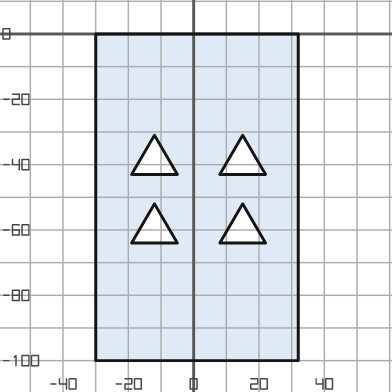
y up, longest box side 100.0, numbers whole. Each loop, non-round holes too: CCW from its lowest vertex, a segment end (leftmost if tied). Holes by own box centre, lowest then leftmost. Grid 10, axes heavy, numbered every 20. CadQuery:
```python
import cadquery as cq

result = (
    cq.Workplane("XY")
    .moveTo(-30.0, -100.0)
    .lineTo(32.0, -100.0)
    .lineTo(32.0, 0.0)
    .lineTo(-30.0, 0.0)
    .close()
    .moveTo(-19.0, -64.0)
    .lineTo(-5.0, -64.0)
    .lineTo(-12.0, -52.0)
    .close()
    .moveTo(8.0, -64.0)
    .lineTo(22.0, -64.0)
    .lineTo(15.0, -52.0)
    .close()
    .moveTo(-19.0, -43.0)
    .lineTo(-5.0, -43.0)
    .lineTo(-12.0, -31.0)
    .close()
    .moveTo(8.0, -43.0)
    .lineTo(22.0, -43.0)
    .lineTo(15.0, -31.0)
    .close()
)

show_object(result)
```